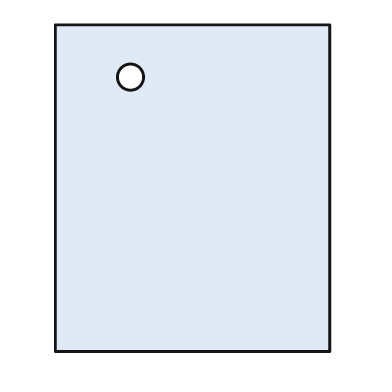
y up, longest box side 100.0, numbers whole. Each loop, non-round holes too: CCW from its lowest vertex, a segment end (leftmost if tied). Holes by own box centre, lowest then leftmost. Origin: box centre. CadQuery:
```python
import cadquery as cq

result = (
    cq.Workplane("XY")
    .moveTo(-42.0, -50.0)
    .lineTo(42.0, -50.0)
    .lineTo(42.0, 50.0)
    .lineTo(-42.0, 50.0)
    .close()
    .moveTo(-19.0, 34.0)
    .circle(4.0)
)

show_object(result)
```